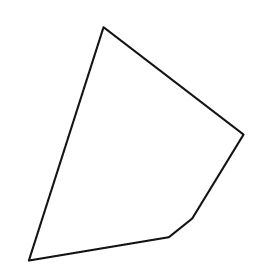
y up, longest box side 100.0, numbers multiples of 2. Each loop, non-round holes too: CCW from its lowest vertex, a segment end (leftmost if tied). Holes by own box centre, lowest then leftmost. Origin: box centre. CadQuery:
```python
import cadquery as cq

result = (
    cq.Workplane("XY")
    .moveTo(-46.0, -50.0)
    .lineTo(14.0, -40.0)
    .lineTo(24.0, -32.0)
    .lineTo(46.0, 4.0)
    .lineTo(-14.0, 50.0)
    .close()
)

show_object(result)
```